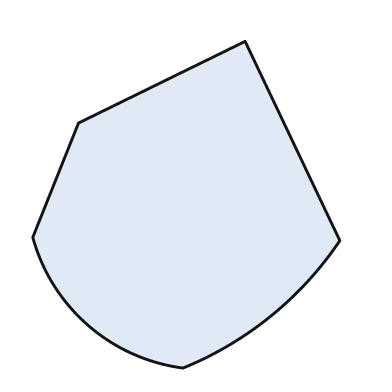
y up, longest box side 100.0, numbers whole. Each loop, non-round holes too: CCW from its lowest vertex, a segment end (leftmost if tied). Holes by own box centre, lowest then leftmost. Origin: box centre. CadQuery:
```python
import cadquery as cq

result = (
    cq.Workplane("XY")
    .moveTo(-1.0, -50.0)
    .threePointArc((26.0, -34.0), (47.0, -11.0))
    .lineTo(18.0, 50.0)
    .lineTo(-33.0, 25.0)
    .lineTo(-47.0, -10.0)
    .threePointArc((-30.0, -37.0), (-1.0, -50.0))
    .close()
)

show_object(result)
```